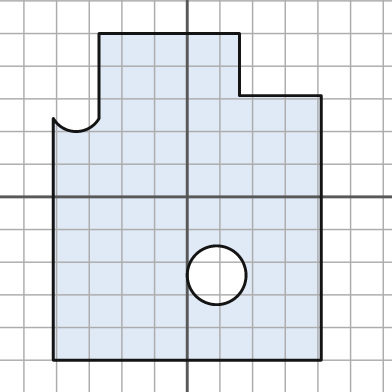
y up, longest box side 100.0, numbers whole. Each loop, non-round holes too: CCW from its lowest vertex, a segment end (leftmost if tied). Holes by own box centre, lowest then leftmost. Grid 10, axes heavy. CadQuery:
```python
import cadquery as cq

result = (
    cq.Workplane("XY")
    .moveTo(-41.0, -50.0)
    .lineTo(41.0, -50.0)
    .lineTo(41.0, 31.0)
    .lineTo(16.0, 31.0)
    .lineTo(16.0, 50.0)
    .lineTo(-27.0, 50.0)
    .lineTo(-27.0, 24.0)
    .threePointArc((-34.0, 20.0), (-41.0, 24.0))
    .close()
    .moveTo(9.0, -24.0)
    .circle(9.0)
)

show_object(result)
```